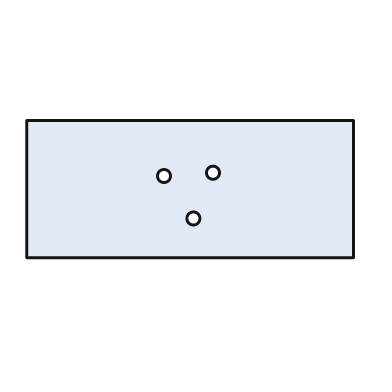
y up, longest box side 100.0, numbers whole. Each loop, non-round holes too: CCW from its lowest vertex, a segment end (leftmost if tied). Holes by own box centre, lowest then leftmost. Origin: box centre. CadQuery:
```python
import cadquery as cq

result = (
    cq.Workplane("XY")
    .moveTo(-50.0, -21.0)
    .lineTo(50.0, -21.0)
    .lineTo(50.0, 21.0)
    .lineTo(-50.0, 21.0)
    .close()
    .moveTo(1.0, -9.0)
    .circle(2.0)
    .moveTo(-8.0, 4.0)
    .circle(2.0)
    .moveTo(7.0, 5.0)
    .circle(2.0)
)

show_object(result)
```